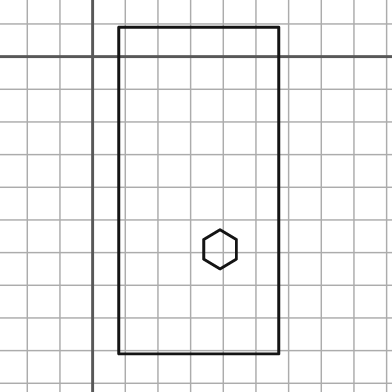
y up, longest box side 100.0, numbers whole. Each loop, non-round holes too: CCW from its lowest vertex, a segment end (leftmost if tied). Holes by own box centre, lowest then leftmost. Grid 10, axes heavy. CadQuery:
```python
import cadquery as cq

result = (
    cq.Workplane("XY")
    .moveTo(8.0, -91.0)
    .lineTo(57.0, -91.0)
    .lineTo(57.0, 9.0)
    .lineTo(8.0, 9.0)
    .close()
    .moveTo(39.0, -65.0)
    .lineTo(44.0, -62.0)
    .lineTo(44.0, -56.0)
    .lineTo(39.0, -53.0)
    .lineTo(34.0, -56.0)
    .lineTo(34.0, -62.0)
    .close()
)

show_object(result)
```